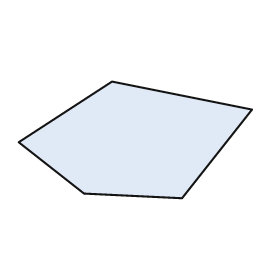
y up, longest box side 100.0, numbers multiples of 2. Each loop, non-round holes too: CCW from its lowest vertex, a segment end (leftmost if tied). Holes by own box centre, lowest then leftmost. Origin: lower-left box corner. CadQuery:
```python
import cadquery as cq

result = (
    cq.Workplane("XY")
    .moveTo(70.0, 0.0)
    .lineTo(100.0, 38.0)
    .lineTo(40.0, 50.0)
    .lineTo(0.0, 24.0)
    .lineTo(28.0, 2.0)
    .close()
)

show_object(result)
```